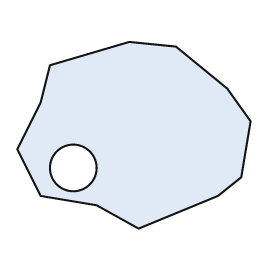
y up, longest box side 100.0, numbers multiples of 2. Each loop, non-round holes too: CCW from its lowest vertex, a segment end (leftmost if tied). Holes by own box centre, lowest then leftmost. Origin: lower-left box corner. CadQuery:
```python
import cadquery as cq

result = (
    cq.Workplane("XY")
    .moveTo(52.0, 0.0)
    .lineTo(86.0, 14.0)
    .lineTo(96.0, 22.0)
    .lineTo(100.0, 46.0)
    .lineTo(90.0, 60.0)
    .lineTo(68.0, 78.0)
    .lineTo(48.0, 80.0)
    .lineTo(14.0, 70.0)
    .lineTo(10.0, 54.0)
    .lineTo(0.0, 34.0)
    .lineTo(10.0, 14.0)
    .lineTo(34.0, 10.0)
    .close()
    .moveTo(24.0, 26.0)
    .circle(10.0)
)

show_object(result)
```